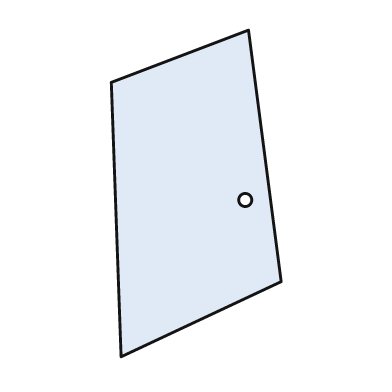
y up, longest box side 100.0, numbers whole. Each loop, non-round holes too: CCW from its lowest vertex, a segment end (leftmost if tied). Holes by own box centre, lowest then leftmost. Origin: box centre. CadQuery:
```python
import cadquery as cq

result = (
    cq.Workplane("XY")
    .moveTo(-23.0, -50.0)
    .lineTo(26.0, -27.0)
    .lineTo(16.0, 50.0)
    .lineTo(-26.0, 34.0)
    .close()
    .moveTo(15.0, -2.0)
    .circle(2.0)
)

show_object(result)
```